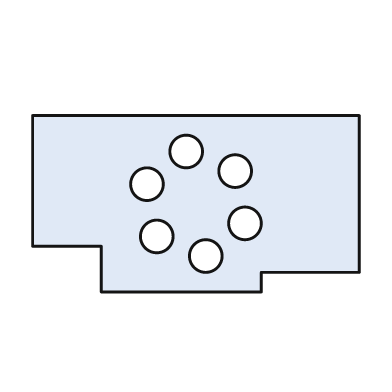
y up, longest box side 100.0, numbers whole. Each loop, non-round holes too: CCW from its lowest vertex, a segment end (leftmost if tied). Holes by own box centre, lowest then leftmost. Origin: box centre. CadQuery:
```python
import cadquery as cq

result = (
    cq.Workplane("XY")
    .moveTo(-29.0, -27.0)
    .lineTo(20.0, -27.0)
    .lineTo(20.0, -21.0)
    .lineTo(50.0, -21.0)
    .lineTo(50.0, 27.0)
    .lineTo(-50.0, 27.0)
    .lineTo(-50.0, -13.0)
    .lineTo(-29.0, -13.0)
    .close()
    .moveTo(3.0, -16.0)
    .circle(5.0)
    .moveTo(-12.0, -10.0)
    .circle(5.0)
    .moveTo(15.0, -6.0)
    .circle(5.0)
    .moveTo(-15.0, 6.0)
    .circle(5.0)
    .moveTo(12.0, 10.0)
    .circle(5.0)
    .moveTo(-3.0, 16.0)
    .circle(5.0)
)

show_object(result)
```